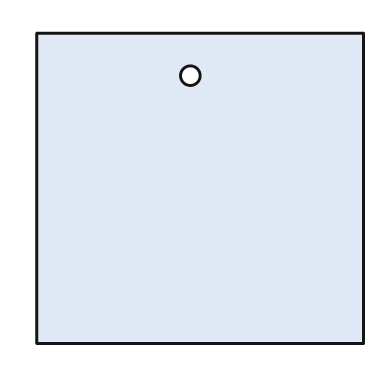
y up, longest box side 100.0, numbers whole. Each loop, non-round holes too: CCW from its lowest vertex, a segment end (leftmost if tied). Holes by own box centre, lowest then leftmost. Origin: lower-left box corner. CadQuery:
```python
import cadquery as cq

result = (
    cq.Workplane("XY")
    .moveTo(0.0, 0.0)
    .lineTo(100.0, 0.0)
    .lineTo(100.0, 95.0)
    .lineTo(0.0, 95.0)
    .close()
    .moveTo(47.0, 82.0)
    .circle(3.0)
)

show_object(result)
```